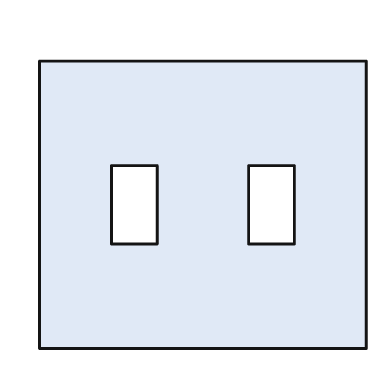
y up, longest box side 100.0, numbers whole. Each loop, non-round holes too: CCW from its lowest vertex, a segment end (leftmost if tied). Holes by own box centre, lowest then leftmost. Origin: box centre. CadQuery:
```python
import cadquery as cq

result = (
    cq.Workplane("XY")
    .moveTo(-50.0, -44.0)
    .lineTo(50.0, -44.0)
    .lineTo(50.0, 44.0)
    .lineTo(-50.0, 44.0)
    .close()
    .moveTo(-28.0, -12.0)
    .lineTo(-14.0, -12.0)
    .lineTo(-14.0, 12.0)
    .lineTo(-28.0, 12.0)
    .close()
    .moveTo(14.0, -12.0)
    .lineTo(28.0, -12.0)
    .lineTo(28.0, 12.0)
    .lineTo(14.0, 12.0)
    .close()
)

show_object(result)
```